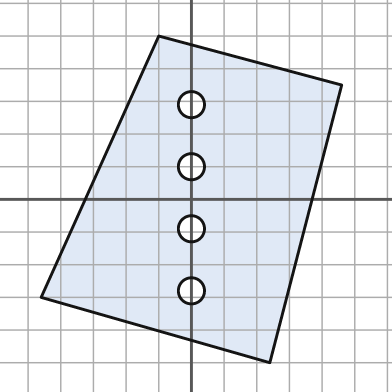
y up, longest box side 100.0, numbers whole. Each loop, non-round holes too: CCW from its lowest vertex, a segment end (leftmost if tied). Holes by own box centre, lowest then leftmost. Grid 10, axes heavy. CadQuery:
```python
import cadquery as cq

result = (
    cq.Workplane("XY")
    .moveTo(24.0, -50.0)
    .lineTo(46.0, 35.0)
    .lineTo(-10.0, 50.0)
    .lineTo(-46.0, -30.0)
    .close()
    .moveTo(0.0, -28.0)
    .circle(4.0)
    .moveTo(0.0, -9.0)
    .circle(4.0)
    .moveTo(0.0, 10.0)
    .circle(4.0)
    .moveTo(0.0, 29.0)
    .circle(4.0)
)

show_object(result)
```